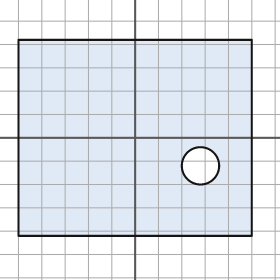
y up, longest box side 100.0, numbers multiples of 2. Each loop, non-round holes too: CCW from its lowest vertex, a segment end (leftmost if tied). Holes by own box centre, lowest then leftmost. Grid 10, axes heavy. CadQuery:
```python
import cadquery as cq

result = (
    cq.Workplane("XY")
    .moveTo(-50.0, -42.0)
    .lineTo(50.0, -42.0)
    .lineTo(50.0, 42.0)
    .lineTo(-50.0, 42.0)
    .close()
    .moveTo(28.0, -12.0)
    .circle(8.0)
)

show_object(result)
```